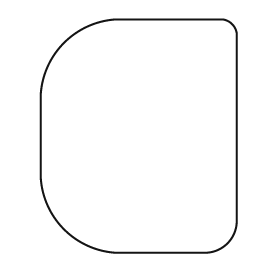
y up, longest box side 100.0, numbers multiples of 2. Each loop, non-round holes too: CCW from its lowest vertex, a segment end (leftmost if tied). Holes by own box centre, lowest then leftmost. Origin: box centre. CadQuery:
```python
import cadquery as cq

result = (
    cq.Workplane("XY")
    .moveTo(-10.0, -50.0)
    .lineTo(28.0, -50.0)
    .threePointArc((38.0, -46.0), (42.0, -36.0))
    .lineTo(42.0, 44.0)
    .threePointArc((40.0, 48.0), (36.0, 50.0))
    .lineTo(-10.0, 50.0)
    .threePointArc((-32.0, 40.0), (-42.0, 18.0))
    .lineTo(-42.0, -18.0)
    .threePointArc((-32.0, -40.0), (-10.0, -50.0))
    .close()
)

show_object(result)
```